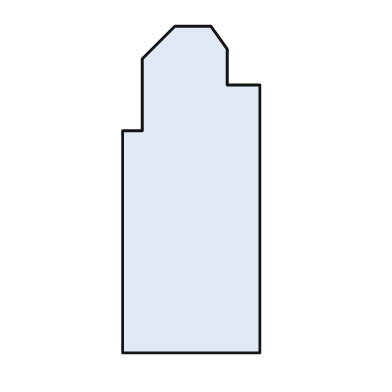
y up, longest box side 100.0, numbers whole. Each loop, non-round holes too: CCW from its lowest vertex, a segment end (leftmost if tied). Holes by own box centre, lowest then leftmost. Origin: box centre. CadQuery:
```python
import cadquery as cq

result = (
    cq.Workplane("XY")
    .moveTo(-21.0, -50.0)
    .lineTo(21.0, -50.0)
    .lineTo(21.0, 32.0)
    .lineTo(11.0, 32.0)
    .lineTo(11.0, 43.0)
    .lineTo(6.0, 50.0)
    .lineTo(-5.0, 50.0)
    .lineTo(-15.0, 40.0)
    .lineTo(-15.0, 18.0)
    .lineTo(-21.0, 18.0)
    .close()
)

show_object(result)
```